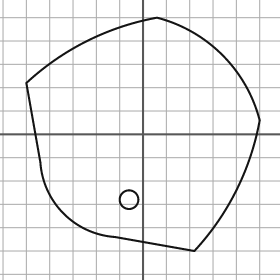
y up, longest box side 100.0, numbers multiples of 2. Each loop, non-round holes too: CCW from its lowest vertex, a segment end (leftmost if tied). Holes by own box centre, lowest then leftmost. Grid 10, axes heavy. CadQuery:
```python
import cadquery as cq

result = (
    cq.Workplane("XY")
    .moveTo(22.0, -50.0)
    .threePointArc((40.0, -24.0), (50.0, 6.0))
    .threePointArc((34.0, 34.0), (6.0, 50.0))
    .threePointArc((-24.0, 40.0), (-50.0, 22.0))
    .lineTo(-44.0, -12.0)
    .threePointArc((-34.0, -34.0), (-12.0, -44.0))
    .close()
    .moveTo(-6.0, -28.0)
    .circle(4.0)
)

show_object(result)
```